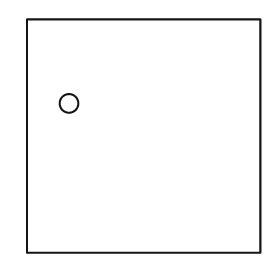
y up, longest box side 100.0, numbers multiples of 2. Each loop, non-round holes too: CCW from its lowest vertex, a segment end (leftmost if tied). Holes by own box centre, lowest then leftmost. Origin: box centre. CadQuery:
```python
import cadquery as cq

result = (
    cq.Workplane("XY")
    .moveTo(-50.0, -50.0)
    .lineTo(50.0, -50.0)
    .lineTo(50.0, 50.0)
    .lineTo(-50.0, 50.0)
    .close()
    .moveTo(-32.0, 14.0)
    .circle(4.0)
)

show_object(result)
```